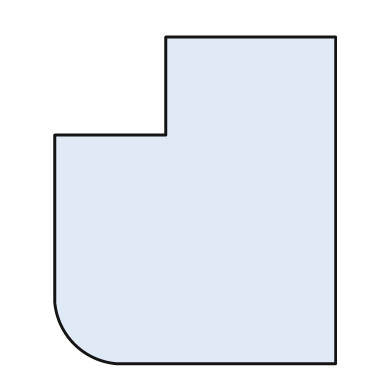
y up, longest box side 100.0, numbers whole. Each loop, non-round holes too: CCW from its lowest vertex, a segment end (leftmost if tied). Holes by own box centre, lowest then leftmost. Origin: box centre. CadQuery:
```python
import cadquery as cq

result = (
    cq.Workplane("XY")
    .moveTo(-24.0, -50.0)
    .lineTo(43.0, -50.0)
    .lineTo(43.0, 50.0)
    .lineTo(-9.0, 50.0)
    .lineTo(-9.0, 20.0)
    .lineTo(-43.0, 20.0)
    .lineTo(-43.0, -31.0)
    .threePointArc((-37.0, -44.0), (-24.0, -50.0))
    .close()
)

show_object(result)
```